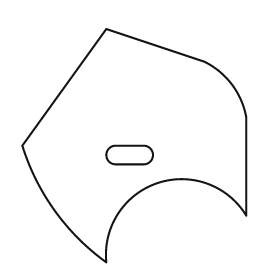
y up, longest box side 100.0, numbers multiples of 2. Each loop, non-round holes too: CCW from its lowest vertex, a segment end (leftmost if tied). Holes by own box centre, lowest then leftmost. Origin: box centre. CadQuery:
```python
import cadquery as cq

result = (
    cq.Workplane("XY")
    .moveTo(-12.0, -50.0)
    .threePointArc((10.0, -16.0), (48.0, -30.0))
    .lineTo(48.0, 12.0)
    .threePointArc((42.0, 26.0), (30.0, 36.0))
    .lineTo(-12.0, 50.0)
    .lineTo(-48.0, 0.0)
    .threePointArc((-34.0, -28.0), (-12.0, -50.0))
    .close()
    .moveTo(-8.0, -8.0)
    .lineTo(4.0, -8.0)
    .threePointArc((8.0, -4.0), (4.0, 0.0))
    .lineTo(-8.0, 0.0)
    .threePointArc((-12.0, -4.0), (-8.0, -8.0))
    .close()
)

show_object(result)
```